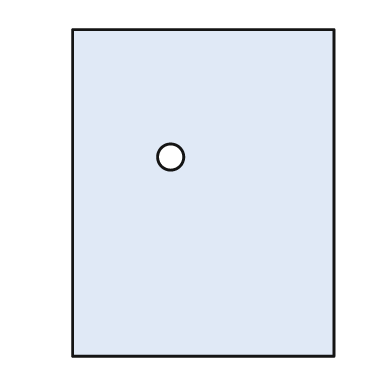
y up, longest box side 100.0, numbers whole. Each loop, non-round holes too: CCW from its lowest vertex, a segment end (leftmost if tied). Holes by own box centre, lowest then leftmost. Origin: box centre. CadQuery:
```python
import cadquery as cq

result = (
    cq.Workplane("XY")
    .moveTo(-40.0, -50.0)
    .lineTo(40.0, -50.0)
    .lineTo(40.0, 50.0)
    .lineTo(-40.0, 50.0)
    .close()
    .moveTo(-10.0, 11.0)
    .circle(4.0)
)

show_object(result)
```